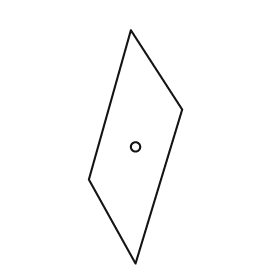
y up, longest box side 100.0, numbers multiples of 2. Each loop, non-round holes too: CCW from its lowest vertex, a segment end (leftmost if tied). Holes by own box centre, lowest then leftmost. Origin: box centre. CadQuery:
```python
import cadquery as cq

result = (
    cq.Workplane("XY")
    .moveTo(0.0, -50.0)
    .lineTo(20.0, 16.0)
    .lineTo(-2.0, 50.0)
    .lineTo(-20.0, -14.0)
    .close()
    .moveTo(0.0, 0.0)
    .circle(2.0)
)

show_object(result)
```